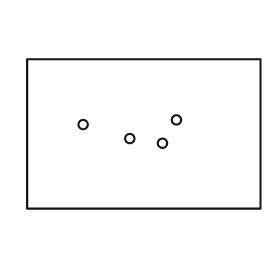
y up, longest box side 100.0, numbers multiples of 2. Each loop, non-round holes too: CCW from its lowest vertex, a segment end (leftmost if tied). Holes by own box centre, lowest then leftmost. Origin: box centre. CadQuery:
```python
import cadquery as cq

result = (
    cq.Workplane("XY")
    .moveTo(-50.0, -32.0)
    .lineTo(50.0, -32.0)
    .lineTo(50.0, 32.0)
    .lineTo(-50.0, 32.0)
    .close()
    .moveTo(8.0, -4.0)
    .circle(2.0)
    .moveTo(-6.0, -2.0)
    .circle(2.0)
    .moveTo(-26.0, 4.0)
    .circle(2.0)
    .moveTo(14.0, 6.0)
    .circle(2.0)
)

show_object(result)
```